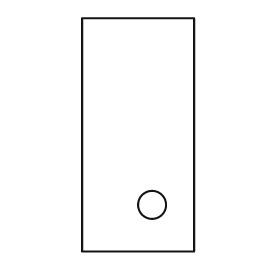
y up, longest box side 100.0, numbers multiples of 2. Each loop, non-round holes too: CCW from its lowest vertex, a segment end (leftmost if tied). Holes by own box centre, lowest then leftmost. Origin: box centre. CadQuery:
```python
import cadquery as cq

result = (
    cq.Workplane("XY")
    .moveTo(-24.0, -50.0)
    .lineTo(24.0, -50.0)
    .lineTo(24.0, 50.0)
    .lineTo(-24.0, 50.0)
    .close()
    .moveTo(6.0, -30.0)
    .circle(6.0)
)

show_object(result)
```